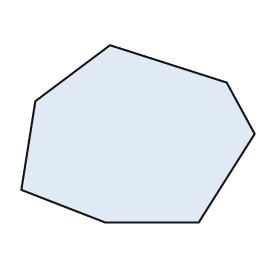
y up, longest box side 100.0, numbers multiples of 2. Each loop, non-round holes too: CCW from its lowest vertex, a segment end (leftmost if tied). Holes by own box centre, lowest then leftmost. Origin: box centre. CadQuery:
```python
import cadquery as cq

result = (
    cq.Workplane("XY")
    .moveTo(-14.0, -38.0)
    .lineTo(26.0, -38.0)
    .lineTo(50.0, 0.0)
    .lineTo(38.0, 22.0)
    .lineTo(-12.0, 38.0)
    .lineTo(-44.0, 14.0)
    .lineTo(-50.0, -24.0)
    .close()
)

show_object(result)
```